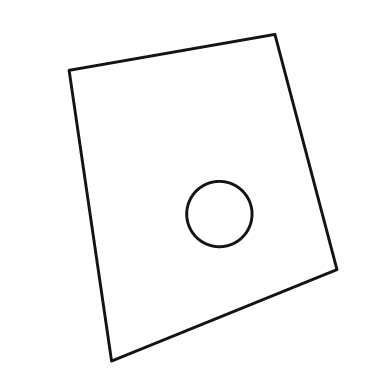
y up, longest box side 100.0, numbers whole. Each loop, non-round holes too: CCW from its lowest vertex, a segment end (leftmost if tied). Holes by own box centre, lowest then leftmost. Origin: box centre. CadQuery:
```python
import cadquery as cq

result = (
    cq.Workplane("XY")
    .moveTo(-28.0, -50.0)
    .lineTo(41.0, -22.0)
    .lineTo(22.0, 50.0)
    .lineTo(-41.0, 39.0)
    .close()
    .moveTo(5.0, -5.0)
    .circle(10.0)
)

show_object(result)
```